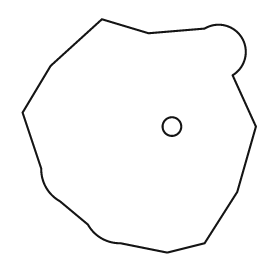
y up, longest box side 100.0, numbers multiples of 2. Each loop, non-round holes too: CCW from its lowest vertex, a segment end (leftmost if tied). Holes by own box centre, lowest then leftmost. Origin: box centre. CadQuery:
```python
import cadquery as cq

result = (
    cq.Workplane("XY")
    .moveTo(12.0, -50.0)
    .lineTo(28.0, -46.0)
    .lineTo(42.0, -24.0)
    .lineTo(50.0, 4.0)
    .lineTo(40.0, 26.0)
    .threePointArc((44.0, 42.0), (28.0, 46.0))
    .lineTo(4.0, 44.0)
    .lineTo(-16.0, 50.0)
    .lineTo(-38.0, 30.0)
    .lineTo(-50.0, 10.0)
    .lineTo(-42.0, -14.0)
    .threePointArc((-40.0, -22.0), (-34.0, -28.0))
    .lineTo(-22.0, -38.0)
    .threePointArc((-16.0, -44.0), (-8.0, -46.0))
    .close()
    .moveTo(14.0, 4.0)
    .circle(4.0)
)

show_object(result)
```